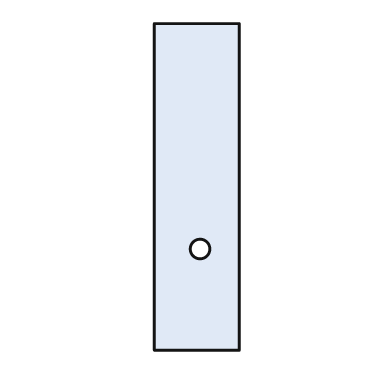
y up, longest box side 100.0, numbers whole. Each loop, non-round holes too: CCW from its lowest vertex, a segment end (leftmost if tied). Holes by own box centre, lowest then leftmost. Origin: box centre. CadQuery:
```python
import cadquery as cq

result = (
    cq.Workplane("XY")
    .moveTo(-13.0, -50.0)
    .lineTo(13.0, -50.0)
    .lineTo(13.0, 50.0)
    .lineTo(-13.0, 50.0)
    .close()
    .moveTo(1.0, -19.0)
    .circle(3.0)
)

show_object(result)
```